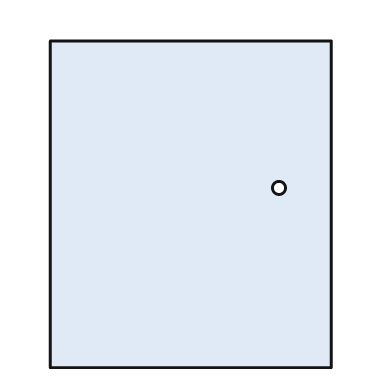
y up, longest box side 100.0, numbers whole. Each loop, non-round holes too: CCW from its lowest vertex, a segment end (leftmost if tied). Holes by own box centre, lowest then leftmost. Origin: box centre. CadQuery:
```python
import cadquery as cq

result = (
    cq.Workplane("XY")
    .moveTo(-43.0, -50.0)
    .lineTo(43.0, -50.0)
    .lineTo(43.0, 50.0)
    .lineTo(-43.0, 50.0)
    .close()
    .moveTo(27.0, 5.0)
    .circle(2.0)
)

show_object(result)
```